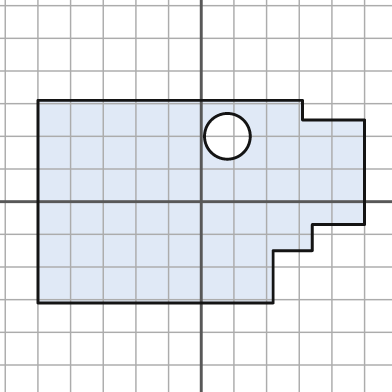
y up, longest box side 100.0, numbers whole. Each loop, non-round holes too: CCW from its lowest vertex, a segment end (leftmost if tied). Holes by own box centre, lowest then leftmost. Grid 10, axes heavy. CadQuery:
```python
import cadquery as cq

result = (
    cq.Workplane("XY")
    .moveTo(-50.0, -31.0)
    .lineTo(22.0, -31.0)
    .lineTo(22.0, -15.0)
    .lineTo(34.0, -15.0)
    .lineTo(34.0, -7.0)
    .lineTo(50.0, -7.0)
    .lineTo(50.0, 25.0)
    .lineTo(31.0, 25.0)
    .lineTo(31.0, 31.0)
    .lineTo(-50.0, 31.0)
    .close()
    .moveTo(8.0, 20.0)
    .circle(7.0)
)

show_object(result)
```